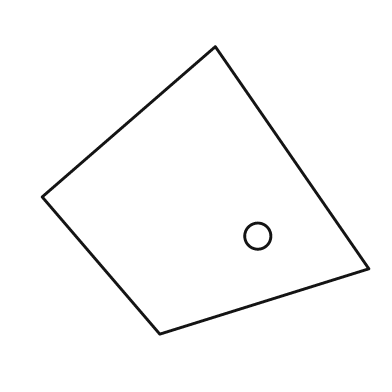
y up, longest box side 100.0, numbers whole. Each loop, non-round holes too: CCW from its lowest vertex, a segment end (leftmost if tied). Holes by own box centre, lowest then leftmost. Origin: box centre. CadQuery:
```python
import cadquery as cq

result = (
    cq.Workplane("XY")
    .moveTo(-14.0, -44.0)
    .lineTo(50.0, -24.0)
    .lineTo(3.0, 44.0)
    .lineTo(-50.0, -2.0)
    .close()
    .moveTo(16.0, -14.0)
    .circle(4.0)
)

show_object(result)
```